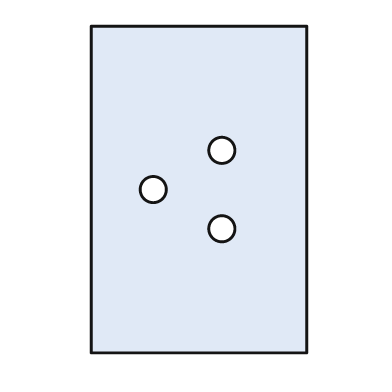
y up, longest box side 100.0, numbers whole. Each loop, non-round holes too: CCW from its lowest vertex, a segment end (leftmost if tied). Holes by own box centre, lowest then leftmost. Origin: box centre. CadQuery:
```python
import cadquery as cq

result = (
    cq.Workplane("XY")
    .moveTo(-33.0, -50.0)
    .lineTo(33.0, -50.0)
    .lineTo(33.0, 50.0)
    .lineTo(-33.0, 50.0)
    .close()
    .moveTo(7.0, -12.0)
    .circle(4.0)
    .moveTo(-14.0, 0.0)
    .circle(4.0)
    .moveTo(7.0, 12.0)
    .circle(4.0)
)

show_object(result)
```